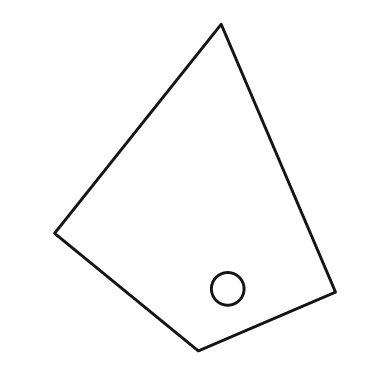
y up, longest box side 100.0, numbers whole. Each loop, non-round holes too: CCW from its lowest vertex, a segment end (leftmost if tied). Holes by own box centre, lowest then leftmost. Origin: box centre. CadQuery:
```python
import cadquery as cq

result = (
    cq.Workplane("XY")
    .moveTo(1.0, -50.0)
    .lineTo(43.0, -32.0)
    .lineTo(8.0, 50.0)
    .lineTo(-43.0, -14.0)
    .close()
    .moveTo(10.0, -31.0)
    .circle(5.0)
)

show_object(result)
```